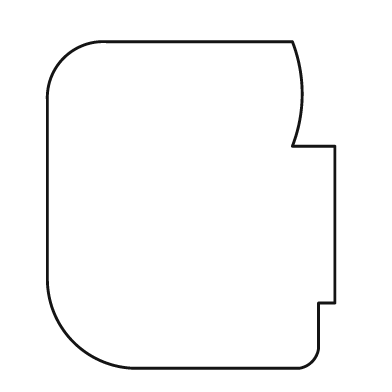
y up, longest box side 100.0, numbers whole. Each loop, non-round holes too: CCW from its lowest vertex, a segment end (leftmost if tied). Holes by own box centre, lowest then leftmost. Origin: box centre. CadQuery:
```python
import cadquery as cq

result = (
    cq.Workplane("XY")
    .moveTo(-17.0, -50.0)
    .lineTo(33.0, -50.0)
    .threePointArc((37.0, -48.0), (39.0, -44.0))
    .lineTo(39.0, -30.0)
    .lineTo(44.0, -30.0)
    .lineTo(44.0, 18.0)
    .lineTo(31.0, 18.0)
    .threePointArc((34.0, 34.0), (31.0, 50.0))
    .lineTo(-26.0, 50.0)
    .threePointArc((-39.0, 45.0), (-44.0, 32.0))
    .lineTo(-44.0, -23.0)
    .threePointArc((-36.0, -42.0), (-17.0, -50.0))
    .close()
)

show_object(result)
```